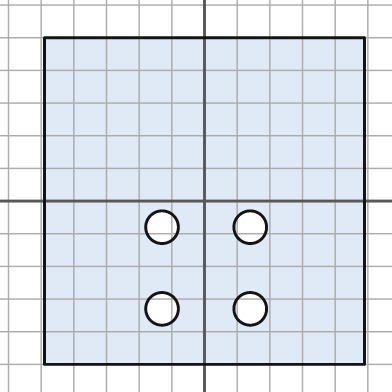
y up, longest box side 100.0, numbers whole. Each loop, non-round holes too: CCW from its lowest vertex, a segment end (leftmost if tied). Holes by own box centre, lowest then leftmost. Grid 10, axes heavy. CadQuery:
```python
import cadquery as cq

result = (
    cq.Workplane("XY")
    .moveTo(-49.0, -50.0)
    .lineTo(49.0, -50.0)
    .lineTo(49.0, 50.0)
    .lineTo(-49.0, 50.0)
    .close()
    .moveTo(-13.0, -33.0)
    .circle(5.0)
    .moveTo(14.0, -33.0)
    .circle(5.0)
    .moveTo(-13.0, -8.0)
    .circle(5.0)
    .moveTo(14.0, -8.0)
    .circle(5.0)
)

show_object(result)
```